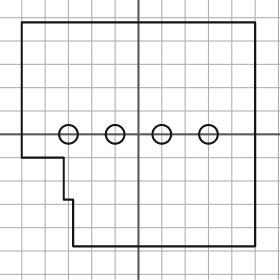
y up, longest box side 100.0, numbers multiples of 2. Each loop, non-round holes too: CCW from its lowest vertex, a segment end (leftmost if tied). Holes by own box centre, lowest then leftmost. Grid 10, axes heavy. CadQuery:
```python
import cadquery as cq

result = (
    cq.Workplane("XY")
    .moveTo(-28.0, -48.0)
    .lineTo(50.0, -48.0)
    .lineTo(50.0, 48.0)
    .lineTo(-50.0, 48.0)
    .lineTo(-50.0, -10.0)
    .lineTo(-32.0, -10.0)
    .lineTo(-32.0, -28.0)
    .lineTo(-28.0, -28.0)
    .close()
    .moveTo(-30.0, 0.0)
    .circle(4.0)
    .moveTo(-10.0, 0.0)
    .circle(4.0)
    .moveTo(10.0, 0.0)
    .circle(4.0)
    .moveTo(30.0, 0.0)
    .circle(4.0)
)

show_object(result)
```